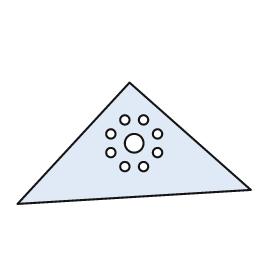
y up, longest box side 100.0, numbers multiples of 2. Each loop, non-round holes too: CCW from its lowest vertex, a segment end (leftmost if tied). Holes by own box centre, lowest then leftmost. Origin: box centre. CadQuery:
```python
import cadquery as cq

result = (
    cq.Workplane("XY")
    .moveTo(-50.0, -26.0)
    .lineTo(50.0, -20.0)
    .lineTo(-2.0, 26.0)
    .close()
    .moveTo(-4.0, -10.0)
    .circle(2.0)
    .moveTo(4.0, -10.0)
    .circle(2.0)
    .moveTo(-10.0, -4.0)
    .circle(2.0)
    .moveTo(10.0, -4.0)
    .circle(2.0)
    .moveTo(0.0, 0.0)
    .circle(4.0)
    .moveTo(-10.0, 4.0)
    .circle(2.0)
    .moveTo(10.0, 4.0)
    .circle(2.0)
    .moveTo(-4.0, 10.0)
    .circle(2.0)
    .moveTo(4.0, 10.0)
    .circle(2.0)
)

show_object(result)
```